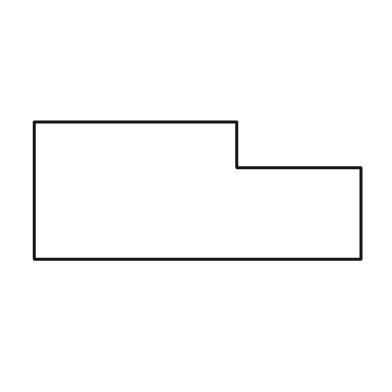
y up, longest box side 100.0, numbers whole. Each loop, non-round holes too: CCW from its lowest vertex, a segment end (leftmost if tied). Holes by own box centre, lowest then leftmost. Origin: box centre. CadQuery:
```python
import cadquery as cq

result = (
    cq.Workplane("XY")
    .moveTo(-50.0, -21.0)
    .lineTo(50.0, -21.0)
    .lineTo(50.0, 7.0)
    .lineTo(12.0, 7.0)
    .lineTo(12.0, 21.0)
    .lineTo(-50.0, 21.0)
    .close()
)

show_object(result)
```